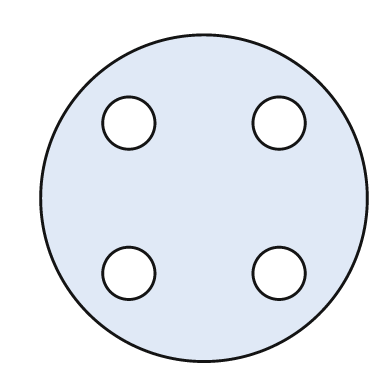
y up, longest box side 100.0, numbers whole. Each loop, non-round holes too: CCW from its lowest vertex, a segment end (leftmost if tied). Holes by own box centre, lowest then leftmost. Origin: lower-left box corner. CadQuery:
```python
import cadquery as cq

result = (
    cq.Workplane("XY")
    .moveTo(50.0, 50.0)
    .circle(50.0)
    .moveTo(27.0, 27.0)
    .circle(8.0)
    .moveTo(73.0, 27.0)
    .circle(8.0)
    .moveTo(27.0, 73.0)
    .circle(8.0)
    .moveTo(73.0, 73.0)
    .circle(8.0)
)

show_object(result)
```